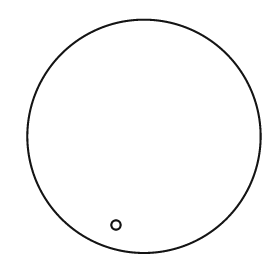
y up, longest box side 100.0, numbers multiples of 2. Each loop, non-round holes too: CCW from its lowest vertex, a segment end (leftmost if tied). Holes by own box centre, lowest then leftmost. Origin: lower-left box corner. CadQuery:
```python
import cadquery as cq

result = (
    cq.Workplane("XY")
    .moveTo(50.0, 50.0)
    .circle(50.0)
    .moveTo(38.0, 12.0)
    .circle(2.0)
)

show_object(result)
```